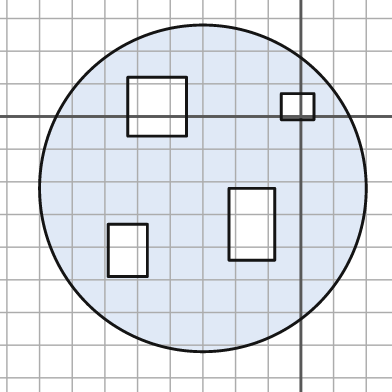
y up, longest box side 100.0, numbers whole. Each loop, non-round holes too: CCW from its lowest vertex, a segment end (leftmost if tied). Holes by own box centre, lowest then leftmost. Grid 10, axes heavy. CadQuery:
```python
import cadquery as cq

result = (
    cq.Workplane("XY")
    .moveTo(-30.0, -22.0)
    .circle(50.0)
    .moveTo(-59.0, -49.0)
    .lineTo(-47.0, -49.0)
    .lineTo(-47.0, -33.0)
    .lineTo(-59.0, -33.0)
    .close()
    .moveTo(-22.0, -44.0)
    .lineTo(-8.0, -44.0)
    .lineTo(-8.0, -22.0)
    .lineTo(-22.0, -22.0)
    .close()
    .moveTo(-53.0, -6.0)
    .lineTo(-35.0, -6.0)
    .lineTo(-35.0, 12.0)
    .lineTo(-53.0, 12.0)
    .close()
    .moveTo(-6.0, -1.0)
    .lineTo(4.0, -1.0)
    .lineTo(4.0, 7.0)
    .lineTo(-6.0, 7.0)
    .close()
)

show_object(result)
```